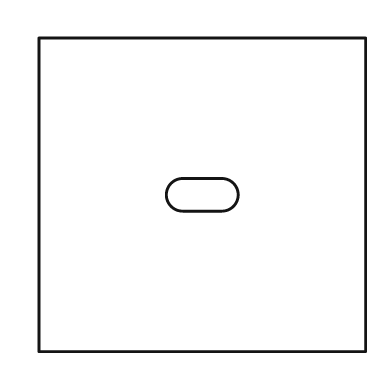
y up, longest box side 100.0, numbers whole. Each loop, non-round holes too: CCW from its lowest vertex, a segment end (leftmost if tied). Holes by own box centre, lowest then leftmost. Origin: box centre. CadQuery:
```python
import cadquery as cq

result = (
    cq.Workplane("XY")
    .moveTo(-50.0, -48.0)
    .lineTo(50.0, -48.0)
    .lineTo(50.0, 48.0)
    .lineTo(-50.0, 48.0)
    .close()
    .moveTo(-6.0, -5.0)
    .lineTo(6.0, -5.0)
    .threePointArc((11.0, 0.0), (6.0, 5.0))
    .lineTo(-6.0, 5.0)
    .threePointArc((-11.0, 0.0), (-6.0, -5.0))
    .close()
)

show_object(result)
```